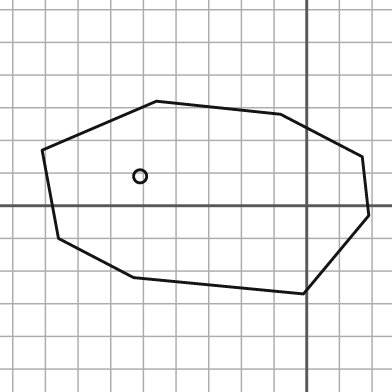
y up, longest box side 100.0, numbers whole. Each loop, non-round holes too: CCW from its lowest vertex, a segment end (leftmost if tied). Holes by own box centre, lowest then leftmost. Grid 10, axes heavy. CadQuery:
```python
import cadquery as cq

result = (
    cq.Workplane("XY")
    .moveTo(-1.0, -27.0)
    .lineTo(19.0, -3.0)
    .lineTo(17.0, 15.0)
    .lineTo(-8.0, 28.0)
    .lineTo(-46.0, 32.0)
    .lineTo(-81.0, 17.0)
    .lineTo(-76.0, -10.0)
    .lineTo(-53.0, -22.0)
    .close()
    .moveTo(-51.0, 9.0)
    .circle(2.0)
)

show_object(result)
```